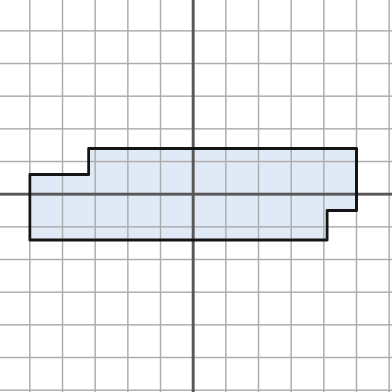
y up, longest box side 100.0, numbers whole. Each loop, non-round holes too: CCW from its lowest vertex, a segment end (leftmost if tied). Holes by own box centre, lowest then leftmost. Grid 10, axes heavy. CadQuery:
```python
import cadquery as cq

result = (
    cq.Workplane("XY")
    .moveTo(-50.0, -14.0)
    .lineTo(41.0, -14.0)
    .lineTo(41.0, -5.0)
    .lineTo(50.0, -5.0)
    .lineTo(50.0, 14.0)
    .lineTo(-32.0, 14.0)
    .lineTo(-32.0, 6.0)
    .lineTo(-50.0, 6.0)
    .close()
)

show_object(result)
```